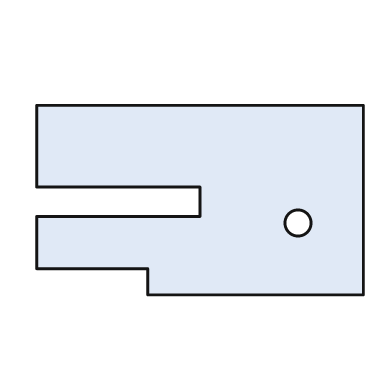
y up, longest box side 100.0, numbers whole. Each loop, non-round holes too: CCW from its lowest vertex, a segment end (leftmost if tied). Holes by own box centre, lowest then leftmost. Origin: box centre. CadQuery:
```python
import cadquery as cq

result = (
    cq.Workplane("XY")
    .moveTo(-16.0, -29.0)
    .lineTo(50.0, -29.0)
    .lineTo(50.0, 29.0)
    .lineTo(-50.0, 29.0)
    .lineTo(-50.0, 4.0)
    .lineTo(0.0, 4.0)
    .lineTo(0.0, -5.0)
    .lineTo(-50.0, -5.0)
    .lineTo(-50.0, -21.0)
    .lineTo(-16.0, -21.0)
    .close()
    .moveTo(30.0, -7.0)
    .circle(4.0)
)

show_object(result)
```